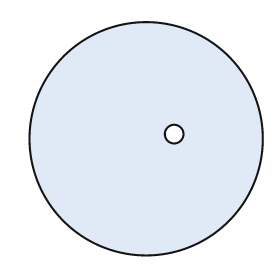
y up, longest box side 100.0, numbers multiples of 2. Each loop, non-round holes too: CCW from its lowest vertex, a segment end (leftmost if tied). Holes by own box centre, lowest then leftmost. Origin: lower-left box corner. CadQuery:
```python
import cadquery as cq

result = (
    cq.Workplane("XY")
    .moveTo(50.0, 50.0)
    .circle(50.0)
    .moveTo(62.0, 52.0)
    .circle(4.0)
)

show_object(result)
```